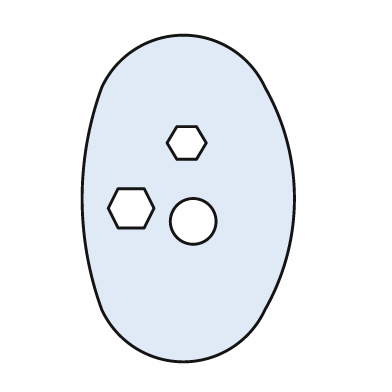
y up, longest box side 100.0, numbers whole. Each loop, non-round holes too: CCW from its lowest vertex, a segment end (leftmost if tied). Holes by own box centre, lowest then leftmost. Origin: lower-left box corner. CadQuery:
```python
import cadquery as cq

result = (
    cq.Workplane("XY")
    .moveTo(6.0, 16.0)
    .threePointArc((31.0, 0.0), (56.0, 16.0))
    .threePointArc((65.0, 50.0), (56.0, 84.0))
    .threePointArc((31.0, 100.0), (6.0, 84.0))
    .threePointArc((0.0, 50.0), (6.0, 16.0))
    .close()
    .moveTo(34.0, 43.0)
    .circle(7.0)
    .moveTo(11.0, 41.0)
    .lineTo(19.0, 41.0)
    .lineTo(22.0, 47.0)
    .lineTo(19.0, 53.0)
    .lineTo(11.0, 53.0)
    .lineTo(8.0, 47.0)
    .close()
    .moveTo(29.0, 62.0)
    .lineTo(35.0, 62.0)
    .lineTo(38.0, 67.0)
    .lineTo(35.0, 72.0)
    .lineTo(29.0, 72.0)
    .lineTo(26.0, 67.0)
    .close()
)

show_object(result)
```